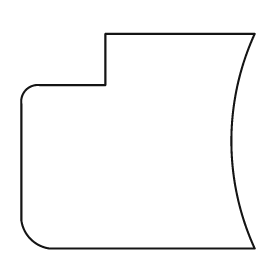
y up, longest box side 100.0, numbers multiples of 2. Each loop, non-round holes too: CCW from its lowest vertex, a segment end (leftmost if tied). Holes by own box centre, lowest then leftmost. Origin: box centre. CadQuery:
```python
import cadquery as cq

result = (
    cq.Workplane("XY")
    .moveTo(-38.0, -46.0)
    .lineTo(50.0, -46.0)
    .threePointArc((40.0, 0.0), (50.0, 46.0))
    .lineTo(-14.0, 46.0)
    .lineTo(-14.0, 24.0)
    .lineTo(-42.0, 24.0)
    .threePointArc((-48.0, 22.0), (-50.0, 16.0))
    .lineTo(-50.0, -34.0)
    .threePointArc((-46.0, -42.0), (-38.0, -46.0))
    .close()
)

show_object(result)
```